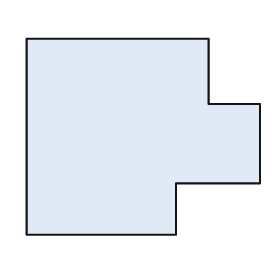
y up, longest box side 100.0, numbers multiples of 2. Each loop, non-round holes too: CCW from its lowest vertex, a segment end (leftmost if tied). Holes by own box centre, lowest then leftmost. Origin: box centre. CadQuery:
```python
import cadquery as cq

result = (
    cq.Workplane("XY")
    .moveTo(-50.0, -42.0)
    .lineTo(14.0, -42.0)
    .lineTo(14.0, -20.0)
    .lineTo(50.0, -20.0)
    .lineTo(50.0, 14.0)
    .lineTo(28.0, 14.0)
    .lineTo(28.0, 42.0)
    .lineTo(-50.0, 42.0)
    .close()
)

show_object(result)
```